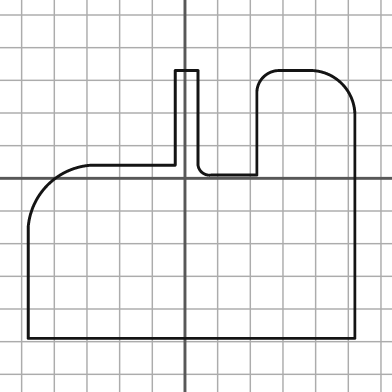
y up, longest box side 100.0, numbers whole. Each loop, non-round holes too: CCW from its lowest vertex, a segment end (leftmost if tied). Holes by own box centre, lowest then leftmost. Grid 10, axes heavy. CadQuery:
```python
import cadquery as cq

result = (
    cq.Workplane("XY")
    .moveTo(-48.0, -49.0)
    .lineTo(52.0, -49.0)
    .lineTo(52.0, 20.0)
    .threePointArc((48.0, 29.0), (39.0, 33.0))
    .lineTo(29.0, 33.0)
    .threePointArc((24.0, 31.0), (22.0, 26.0))
    .lineTo(22.0, 1.0)
    .lineTo(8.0, 1.0)
    .threePointArc((5.0, 2.0), (4.0, 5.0))
    .lineTo(4.0, 33.0)
    .lineTo(-3.0, 33.0)
    .lineTo(-3.0, 4.0)
    .lineTo(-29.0, 4.0)
    .threePointArc((-42.0, -2.0), (-48.0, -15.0))
    .close()
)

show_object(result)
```